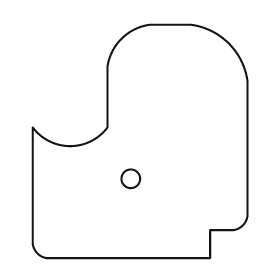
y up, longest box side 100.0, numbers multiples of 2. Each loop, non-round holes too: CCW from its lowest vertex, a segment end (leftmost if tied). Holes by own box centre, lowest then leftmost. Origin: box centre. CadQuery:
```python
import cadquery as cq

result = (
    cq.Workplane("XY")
    .moveTo(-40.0, -50.0)
    .lineTo(30.0, -50.0)
    .lineTo(30.0, -38.0)
    .lineTo(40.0, -38.0)
    .threePointArc((44.0, -36.0), (46.0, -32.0))
    .lineTo(46.0, 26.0)
    .threePointArc((38.0, 42.0), (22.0, 50.0))
    .lineTo(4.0, 50.0)
    .threePointArc((-8.0, 44.0), (-14.0, 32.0))
    .lineTo(-14.0, 6.0)
    .threePointArc((-30.0, -2.0), (-46.0, 6.0))
    .lineTo(-46.0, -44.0)
    .threePointArc((-44.0, -48.0), (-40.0, -50.0))
    .close()
    .moveTo(-4.0, -16.0)
    .circle(4.0)
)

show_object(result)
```